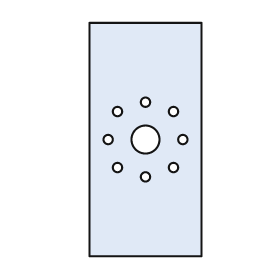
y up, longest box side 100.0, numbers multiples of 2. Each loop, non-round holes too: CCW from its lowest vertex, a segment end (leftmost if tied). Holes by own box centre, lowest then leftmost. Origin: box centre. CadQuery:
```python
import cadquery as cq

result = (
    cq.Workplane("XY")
    .moveTo(-24.0, -50.0)
    .lineTo(24.0, -50.0)
    .lineTo(24.0, 50.0)
    .lineTo(-24.0, 50.0)
    .close()
    .moveTo(0.0, -16.0)
    .circle(2.0)
    .moveTo(-12.0, -12.0)
    .circle(2.0)
    .moveTo(12.0, -12.0)
    .circle(2.0)
    .moveTo(-16.0, 0.0)
    .circle(2.0)
    .moveTo(0.0, 0.0)
    .circle(6.0)
    .moveTo(16.0, 0.0)
    .circle(2.0)
    .moveTo(-12.0, 12.0)
    .circle(2.0)
    .moveTo(12.0, 12.0)
    .circle(2.0)
    .moveTo(0.0, 16.0)
    .circle(2.0)
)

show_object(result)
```